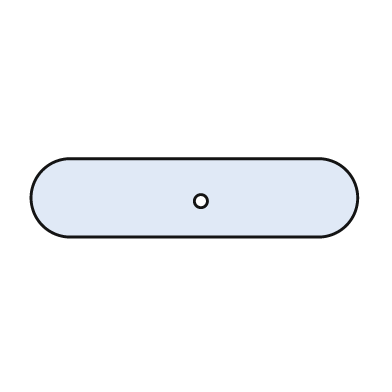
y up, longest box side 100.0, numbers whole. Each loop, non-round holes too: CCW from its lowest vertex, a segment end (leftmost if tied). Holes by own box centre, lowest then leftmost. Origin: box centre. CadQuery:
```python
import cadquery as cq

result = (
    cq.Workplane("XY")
    .moveTo(-38.0, -12.0)
    .lineTo(38.0, -12.0)
    .threePointArc((50.0, 0.0), (38.0, 12.0))
    .lineTo(-38.0, 12.0)
    .threePointArc((-50.0, 0.0), (-38.0, -12.0))
    .close()
    .moveTo(2.0, -1.0)
    .circle(2.0)
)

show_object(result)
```